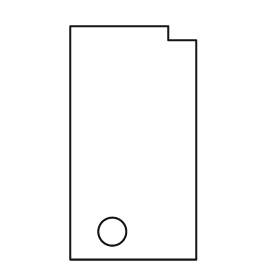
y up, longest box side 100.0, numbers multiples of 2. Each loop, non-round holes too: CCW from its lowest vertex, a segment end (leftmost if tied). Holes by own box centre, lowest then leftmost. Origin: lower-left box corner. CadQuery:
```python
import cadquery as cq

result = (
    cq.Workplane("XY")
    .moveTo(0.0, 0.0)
    .lineTo(54.0, 0.0)
    .lineTo(54.0, 94.0)
    .lineTo(42.0, 94.0)
    .lineTo(42.0, 100.0)
    .lineTo(0.0, 100.0)
    .close()
    .moveTo(18.0, 12.0)
    .circle(6.0)
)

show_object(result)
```